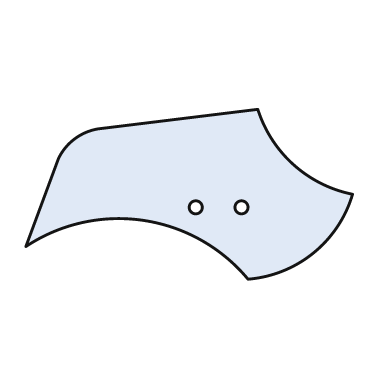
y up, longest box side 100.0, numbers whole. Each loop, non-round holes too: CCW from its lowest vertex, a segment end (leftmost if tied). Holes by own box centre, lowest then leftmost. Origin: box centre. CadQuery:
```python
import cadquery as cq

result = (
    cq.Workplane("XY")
    .moveTo(18.0, -26.0)
    .threePointArc((38.0, -18.0), (50.0, 0.0))
    .threePointArc((32.0, 9.0), (21.0, 26.0))
    .lineTo(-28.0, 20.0)
    .threePointArc((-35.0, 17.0), (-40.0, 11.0))
    .lineTo(-50.0, -16.0)
    .threePointArc((-14.0, -8.0), (18.0, -26.0))
    .close()
    .moveTo(2.0, -4.0)
    .circle(2.0)
    .moveTo(16.0, -4.0)
    .circle(2.0)
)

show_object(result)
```